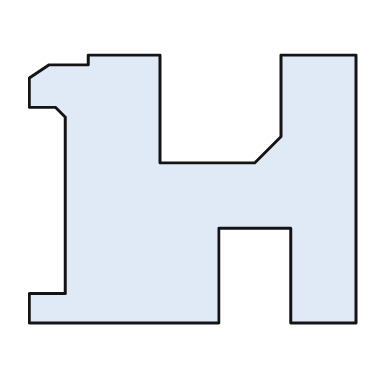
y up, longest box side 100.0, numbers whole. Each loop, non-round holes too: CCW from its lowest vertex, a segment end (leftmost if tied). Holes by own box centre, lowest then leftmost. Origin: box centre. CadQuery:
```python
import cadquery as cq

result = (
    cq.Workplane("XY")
    .moveTo(-50.0, -41.0)
    .lineTo(8.0, -41.0)
    .lineTo(8.0, -12.0)
    .lineTo(30.0, -12.0)
    .lineTo(30.0, -41.0)
    .lineTo(50.0, -41.0)
    .lineTo(50.0, 41.0)
    .lineTo(27.0, 41.0)
    .lineTo(27.0, 16.0)
    .lineTo(19.0, 8.0)
    .lineTo(-10.0, 8.0)
    .lineTo(-10.0, 41.0)
    .lineTo(-32.0, 41.0)
    .lineTo(-32.0, 38.0)
    .lineTo(-44.0, 38.0)
    .lineTo(-50.0, 34.0)
    .lineTo(-50.0, 25.0)
    .lineTo(-42.0, 25.0)
    .lineTo(-39.0, 22.0)
    .lineTo(-39.0, -32.0)
    .lineTo(-50.0, -32.0)
    .close()
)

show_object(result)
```